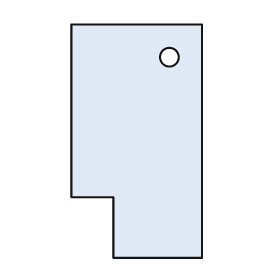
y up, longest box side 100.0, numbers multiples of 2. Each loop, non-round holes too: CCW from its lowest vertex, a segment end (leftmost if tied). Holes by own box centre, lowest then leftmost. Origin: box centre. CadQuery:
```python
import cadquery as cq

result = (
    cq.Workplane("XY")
    .moveTo(-10.0, -50.0)
    .lineTo(28.0, -50.0)
    .lineTo(28.0, 50.0)
    .lineTo(-28.0, 50.0)
    .lineTo(-28.0, -24.0)
    .lineTo(-10.0, -24.0)
    .close()
    .moveTo(14.0, 36.0)
    .circle(4.0)
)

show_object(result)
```